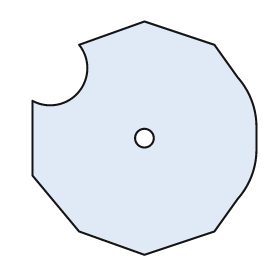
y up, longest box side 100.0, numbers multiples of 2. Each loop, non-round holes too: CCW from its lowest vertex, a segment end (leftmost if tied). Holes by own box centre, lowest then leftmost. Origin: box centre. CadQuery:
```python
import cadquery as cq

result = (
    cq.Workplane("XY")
    .moveTo(0.0, -50.0)
    .lineTo(30.0, -40.0)
    .lineTo(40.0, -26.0)
    .threePointArc((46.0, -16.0), (48.0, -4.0))
    .lineTo(48.0, 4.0)
    .threePointArc((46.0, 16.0), (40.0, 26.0))
    .lineTo(30.0, 40.0)
    .lineTo(0.0, 50.0)
    .lineTo(-28.0, 40.0)
    .threePointArc((-28.0, 20.0), (-48.0, 16.0))
    .lineTo(-48.0, -16.0)
    .lineTo(-28.0, -40.0)
    .close()
    .moveTo(0.0, 0.0)
    .circle(4.0)
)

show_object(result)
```